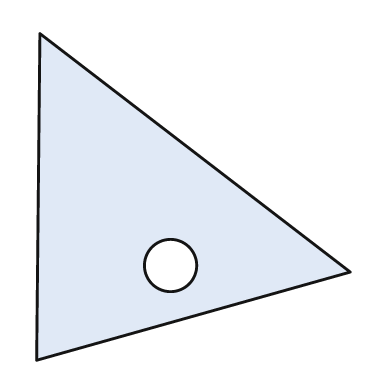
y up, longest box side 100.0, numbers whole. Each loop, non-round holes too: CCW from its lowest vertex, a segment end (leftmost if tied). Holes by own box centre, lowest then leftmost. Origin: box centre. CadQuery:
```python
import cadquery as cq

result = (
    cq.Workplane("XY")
    .moveTo(-48.0, -50.0)
    .lineTo(48.0, -23.0)
    .lineTo(-47.0, 50.0)
    .close()
    .moveTo(-7.0, -21.0)
    .circle(8.0)
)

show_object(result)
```